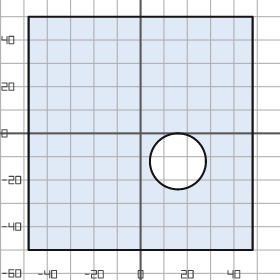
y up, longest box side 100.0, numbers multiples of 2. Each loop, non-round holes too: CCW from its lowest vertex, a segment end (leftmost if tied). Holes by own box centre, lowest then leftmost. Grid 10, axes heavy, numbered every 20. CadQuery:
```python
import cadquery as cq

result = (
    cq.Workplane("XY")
    .moveTo(-48.0, -50.0)
    .lineTo(48.0, -50.0)
    .lineTo(48.0, 50.0)
    .lineTo(-48.0, 50.0)
    .close()
    .moveTo(16.0, -12.0)
    .circle(12.0)
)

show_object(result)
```